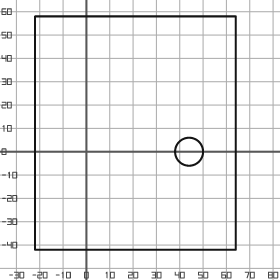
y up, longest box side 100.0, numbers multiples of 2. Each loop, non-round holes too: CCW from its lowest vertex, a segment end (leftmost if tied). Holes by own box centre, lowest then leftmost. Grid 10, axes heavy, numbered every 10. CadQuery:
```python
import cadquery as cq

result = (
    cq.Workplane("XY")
    .moveTo(-22.0, -42.0)
    .lineTo(64.0, -42.0)
    .lineTo(64.0, 58.0)
    .lineTo(-22.0, 58.0)
    .close()
    .moveTo(44.0, 0.0)
    .circle(6.0)
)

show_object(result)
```